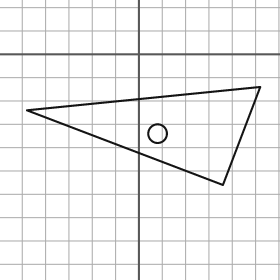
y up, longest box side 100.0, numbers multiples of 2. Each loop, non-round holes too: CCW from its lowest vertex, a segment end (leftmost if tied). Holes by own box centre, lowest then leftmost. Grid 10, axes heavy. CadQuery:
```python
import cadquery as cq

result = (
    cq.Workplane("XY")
    .moveTo(36.0, -56.0)
    .lineTo(52.0, -14.0)
    .lineTo(-48.0, -24.0)
    .close()
    .moveTo(8.0, -34.0)
    .circle(4.0)
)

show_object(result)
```